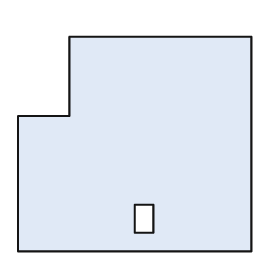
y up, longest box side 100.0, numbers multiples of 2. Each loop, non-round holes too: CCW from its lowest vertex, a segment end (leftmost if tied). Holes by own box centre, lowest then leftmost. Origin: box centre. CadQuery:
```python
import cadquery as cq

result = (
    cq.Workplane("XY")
    .moveTo(-50.0, -46.0)
    .lineTo(50.0, -46.0)
    .lineTo(50.0, 46.0)
    .lineTo(-28.0, 46.0)
    .lineTo(-28.0, 12.0)
    .lineTo(-50.0, 12.0)
    .close()
    .moveTo(0.0, -38.0)
    .lineTo(8.0, -38.0)
    .lineTo(8.0, -26.0)
    .lineTo(0.0, -26.0)
    .close()
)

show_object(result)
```